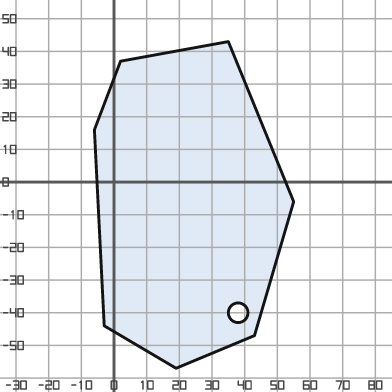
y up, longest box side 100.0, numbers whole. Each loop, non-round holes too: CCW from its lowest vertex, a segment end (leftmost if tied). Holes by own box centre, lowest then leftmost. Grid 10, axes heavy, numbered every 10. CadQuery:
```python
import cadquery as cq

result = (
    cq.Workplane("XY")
    .moveTo(19.0, -57.0)
    .lineTo(43.0, -47.0)
    .lineTo(55.0, -6.0)
    .lineTo(35.0, 43.0)
    .lineTo(2.0, 37.0)
    .lineTo(-6.0, 16.0)
    .lineTo(-3.0, -44.0)
    .close()
    .moveTo(38.0, -40.0)
    .circle(3.0)
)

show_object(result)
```